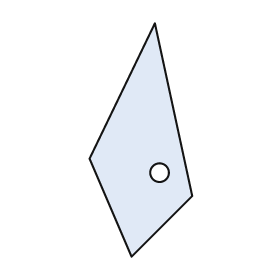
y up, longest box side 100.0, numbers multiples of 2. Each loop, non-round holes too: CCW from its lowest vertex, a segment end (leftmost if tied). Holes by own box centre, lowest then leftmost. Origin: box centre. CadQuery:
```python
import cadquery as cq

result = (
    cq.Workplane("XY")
    .moveTo(-4.0, -50.0)
    .lineTo(22.0, -24.0)
    .lineTo(6.0, 50.0)
    .lineTo(-22.0, -8.0)
    .close()
    .moveTo(8.0, -14.0)
    .circle(4.0)
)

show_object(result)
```